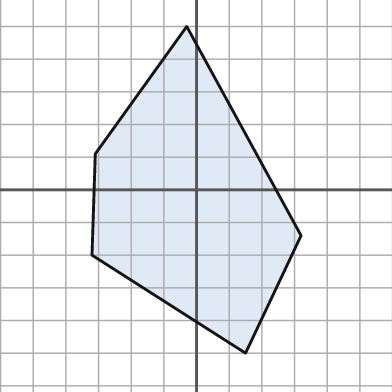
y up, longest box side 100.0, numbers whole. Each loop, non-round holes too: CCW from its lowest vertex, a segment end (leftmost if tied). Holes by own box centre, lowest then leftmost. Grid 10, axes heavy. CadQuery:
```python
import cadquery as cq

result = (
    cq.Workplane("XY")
    .moveTo(15.0, -50.0)
    .lineTo(32.0, -14.0)
    .lineTo(-3.0, 50.0)
    .lineTo(-31.0, 11.0)
    .lineTo(-32.0, -20.0)
    .close()
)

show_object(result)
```